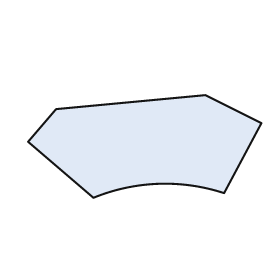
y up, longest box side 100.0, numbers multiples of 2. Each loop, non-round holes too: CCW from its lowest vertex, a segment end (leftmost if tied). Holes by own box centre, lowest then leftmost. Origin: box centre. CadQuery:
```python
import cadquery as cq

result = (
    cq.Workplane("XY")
    .moveTo(-22.0, -22.0)
    .threePointArc((6.0, -16.0), (34.0, -20.0))
    .lineTo(50.0, 10.0)
    .lineTo(26.0, 22.0)
    .lineTo(-38.0, 16.0)
    .lineTo(-50.0, 2.0)
    .close()
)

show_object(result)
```